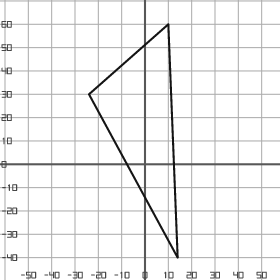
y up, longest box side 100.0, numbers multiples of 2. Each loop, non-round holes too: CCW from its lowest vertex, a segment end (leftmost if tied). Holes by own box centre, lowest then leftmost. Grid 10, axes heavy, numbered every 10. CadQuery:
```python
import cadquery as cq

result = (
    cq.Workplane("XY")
    .moveTo(14.0, -40.0)
    .lineTo(10.0, 60.0)
    .lineTo(-24.0, 30.0)
    .close()
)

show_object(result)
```